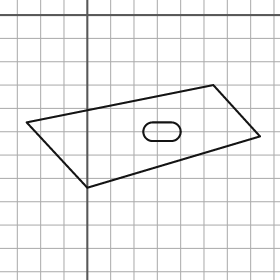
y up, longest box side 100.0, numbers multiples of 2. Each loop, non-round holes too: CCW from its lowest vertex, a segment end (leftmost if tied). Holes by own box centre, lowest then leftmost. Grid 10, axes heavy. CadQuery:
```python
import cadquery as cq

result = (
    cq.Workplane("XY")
    .moveTo(0.0, -74.0)
    .lineTo(74.0, -52.0)
    .lineTo(54.0, -30.0)
    .lineTo(-26.0, -46.0)
    .close()
    .moveTo(28.0, -54.0)
    .lineTo(36.0, -54.0)
    .threePointArc((40.0, -50.0), (36.0, -46.0))
    .lineTo(28.0, -46.0)
    .threePointArc((24.0, -50.0), (28.0, -54.0))
    .close()
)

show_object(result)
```